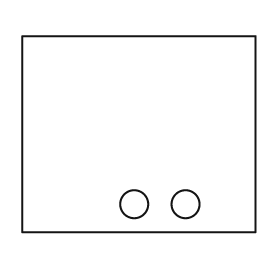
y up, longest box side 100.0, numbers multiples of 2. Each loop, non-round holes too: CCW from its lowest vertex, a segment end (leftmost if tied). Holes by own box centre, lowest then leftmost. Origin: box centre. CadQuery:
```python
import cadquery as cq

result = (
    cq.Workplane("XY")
    .moveTo(-50.0, -42.0)
    .lineTo(50.0, -42.0)
    .lineTo(50.0, 42.0)
    .lineTo(-50.0, 42.0)
    .close()
    .moveTo(-2.0, -30.0)
    .circle(6.0)
    .moveTo(20.0, -30.0)
    .circle(6.0)
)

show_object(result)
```